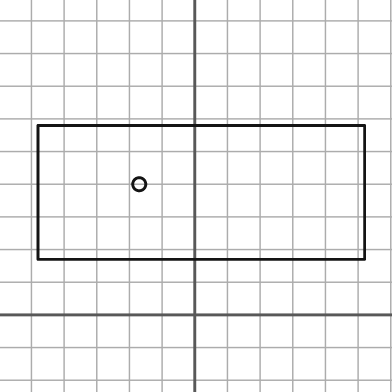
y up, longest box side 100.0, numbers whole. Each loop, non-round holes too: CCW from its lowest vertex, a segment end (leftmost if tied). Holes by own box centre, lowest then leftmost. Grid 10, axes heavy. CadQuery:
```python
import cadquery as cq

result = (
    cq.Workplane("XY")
    .moveTo(-48.0, 17.0)
    .lineTo(52.0, 17.0)
    .lineTo(52.0, 58.0)
    .lineTo(-48.0, 58.0)
    .close()
    .moveTo(-17.0, 40.0)
    .circle(2.0)
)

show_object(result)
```